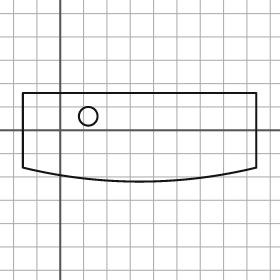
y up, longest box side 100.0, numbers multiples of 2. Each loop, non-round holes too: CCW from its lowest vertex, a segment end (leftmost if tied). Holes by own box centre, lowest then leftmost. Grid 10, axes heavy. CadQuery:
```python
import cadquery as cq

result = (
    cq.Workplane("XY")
    .moveTo(-16.0, -16.0)
    .threePointArc((34.0, -22.0), (84.0, -16.0))
    .lineTo(84.0, 16.0)
    .lineTo(-16.0, 16.0)
    .close()
    .moveTo(12.0, 6.0)
    .circle(4.0)
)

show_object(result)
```